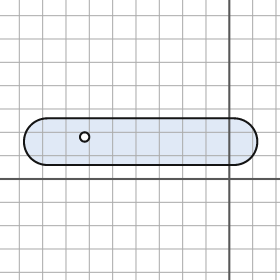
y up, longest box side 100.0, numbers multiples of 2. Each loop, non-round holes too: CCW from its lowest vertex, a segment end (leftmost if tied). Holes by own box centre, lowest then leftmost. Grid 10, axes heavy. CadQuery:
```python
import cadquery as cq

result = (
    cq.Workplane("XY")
    .moveTo(-78.0, 6.0)
    .lineTo(2.0, 6.0)
    .threePointArc((12.0, 16.0), (2.0, 26.0))
    .lineTo(-78.0, 26.0)
    .threePointArc((-88.0, 16.0), (-78.0, 6.0))
    .close()
    .moveTo(-62.0, 18.0)
    .circle(2.0)
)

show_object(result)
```